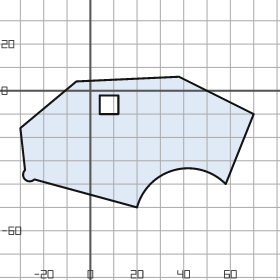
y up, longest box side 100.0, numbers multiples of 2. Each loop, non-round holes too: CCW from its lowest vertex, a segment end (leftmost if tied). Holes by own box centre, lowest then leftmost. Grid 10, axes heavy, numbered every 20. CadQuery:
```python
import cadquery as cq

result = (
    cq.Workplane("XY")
    .moveTo(20.0, -50.0)
    .threePointArc((36.0, -34.0), (58.0, -40.0))
    .lineTo(70.0, -10.0)
    .lineTo(38.0, 6.0)
    .lineTo(-6.0, 4.0)
    .lineTo(-30.0, -16.0)
    .lineTo(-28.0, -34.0)
    .threePointArc((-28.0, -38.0), (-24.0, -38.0))
    .close()
    .moveTo(4.0, -10.0)
    .lineTo(12.0, -10.0)
    .lineTo(12.0, -2.0)
    .lineTo(4.0, -2.0)
    .close()
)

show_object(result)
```